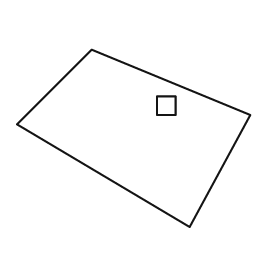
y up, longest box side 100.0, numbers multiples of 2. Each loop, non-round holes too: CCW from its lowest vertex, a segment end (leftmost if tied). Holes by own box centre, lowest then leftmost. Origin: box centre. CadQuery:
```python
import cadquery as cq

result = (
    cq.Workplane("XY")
    .moveTo(24.0, -38.0)
    .lineTo(50.0, 10.0)
    .lineTo(-18.0, 38.0)
    .lineTo(-50.0, 6.0)
    .close()
    .moveTo(10.0, 10.0)
    .lineTo(18.0, 10.0)
    .lineTo(18.0, 18.0)
    .lineTo(10.0, 18.0)
    .close()
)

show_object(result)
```